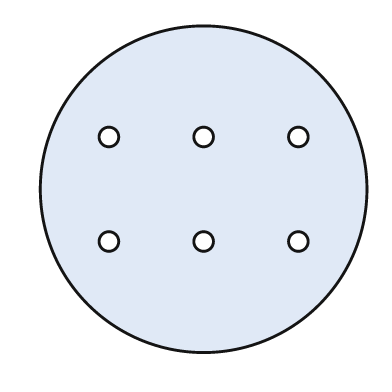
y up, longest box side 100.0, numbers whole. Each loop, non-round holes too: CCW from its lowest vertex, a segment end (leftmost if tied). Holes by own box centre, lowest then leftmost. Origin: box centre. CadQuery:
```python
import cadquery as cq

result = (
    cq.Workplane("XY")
    .moveTo(0.0, 0.0)
    .circle(50.0)
    .moveTo(-29.0, -16.0)
    .circle(3.0)
    .moveTo(0.0, -16.0)
    .circle(3.0)
    .moveTo(29.0, -16.0)
    .circle(3.0)
    .moveTo(-29.0, 16.0)
    .circle(3.0)
    .moveTo(0.0, 16.0)
    .circle(3.0)
    .moveTo(29.0, 16.0)
    .circle(3.0)
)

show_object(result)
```